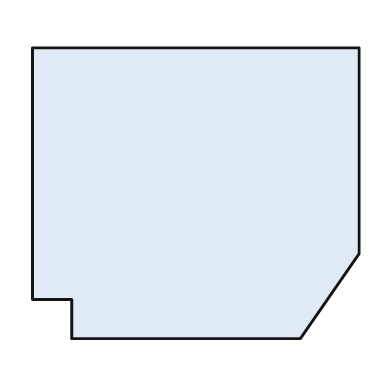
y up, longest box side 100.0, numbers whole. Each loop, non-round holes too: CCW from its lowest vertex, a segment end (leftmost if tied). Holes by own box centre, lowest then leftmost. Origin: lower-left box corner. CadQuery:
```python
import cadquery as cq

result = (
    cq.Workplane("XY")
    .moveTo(12.0, 0.0)
    .lineTo(82.0, 0.0)
    .lineTo(100.0, 26.0)
    .lineTo(100.0, 89.0)
    .lineTo(0.0, 89.0)
    .lineTo(0.0, 12.0)
    .lineTo(12.0, 12.0)
    .close()
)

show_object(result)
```